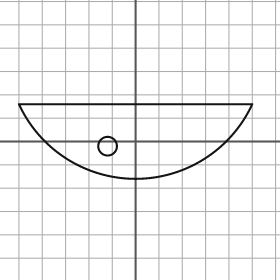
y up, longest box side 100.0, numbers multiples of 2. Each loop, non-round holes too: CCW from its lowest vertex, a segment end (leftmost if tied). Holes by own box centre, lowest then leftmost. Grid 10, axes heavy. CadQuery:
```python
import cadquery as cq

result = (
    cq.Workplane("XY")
    .moveTo(-50.0, 16.0)
    .threePointArc((0.0, -16.0), (50.0, 16.0))
    .close()
    .moveTo(-12.0, -2.0)
    .circle(4.0)
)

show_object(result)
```